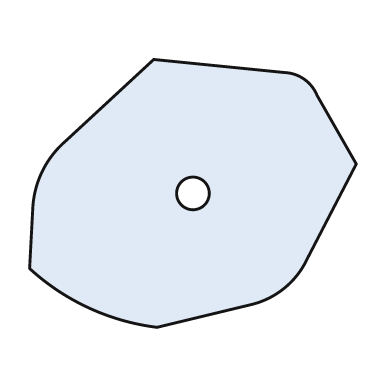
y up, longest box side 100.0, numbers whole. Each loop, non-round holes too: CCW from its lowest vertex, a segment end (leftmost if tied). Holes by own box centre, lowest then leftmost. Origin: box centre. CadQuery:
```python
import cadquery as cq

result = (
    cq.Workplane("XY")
    .moveTo(-11.0, -41.0)
    .lineTo(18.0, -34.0)
    .threePointArc((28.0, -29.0), (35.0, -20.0))
    .lineTo(50.0, 9.0)
    .lineTo(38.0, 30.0)
    .threePointArc((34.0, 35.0), (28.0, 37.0))
    .lineTo(-12.0, 41.0)
    .lineTo(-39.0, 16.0)
    .threePointArc((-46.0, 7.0), (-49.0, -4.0))
    .lineTo(-50.0, -23.0)
    .threePointArc((-32.0, -35.0), (-11.0, -41.0))
    .close()
    .moveTo(0.0, 0.0)
    .circle(5.0)
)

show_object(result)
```